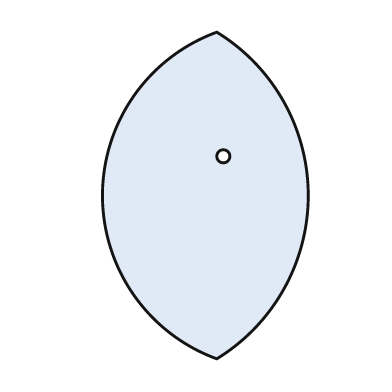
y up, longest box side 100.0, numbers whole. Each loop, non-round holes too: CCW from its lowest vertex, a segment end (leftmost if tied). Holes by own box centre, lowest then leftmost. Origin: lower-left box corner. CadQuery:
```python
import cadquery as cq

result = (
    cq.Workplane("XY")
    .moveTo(35.0, 0.0)
    .threePointArc((63.0, 50.0), (35.0, 100.0))
    .threePointArc((0.0, 50.0), (35.0, 0.0))
    .close()
    .moveTo(37.0, 62.0)
    .circle(2.0)
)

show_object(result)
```